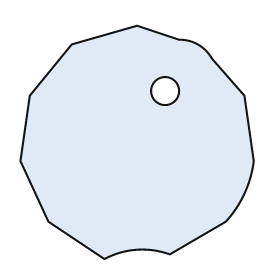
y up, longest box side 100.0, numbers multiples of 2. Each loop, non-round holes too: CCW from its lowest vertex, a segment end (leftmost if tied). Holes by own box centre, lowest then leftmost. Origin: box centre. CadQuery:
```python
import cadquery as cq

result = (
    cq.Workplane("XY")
    .moveTo(-14.0, -50.0)
    .threePointArc((0.0, -46.0), (14.0, -48.0))
    .lineTo(38.0, -34.0)
    .threePointArc((46.0, -22.0), (50.0, -8.0))
    .lineTo(46.0, 20.0)
    .lineTo(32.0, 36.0)
    .threePointArc((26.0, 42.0), (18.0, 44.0))
    .lineTo(0.0, 50.0)
    .lineTo(-28.0, 42.0)
    .lineTo(-46.0, 20.0)
    .lineTo(-50.0, -8.0)
    .lineTo(-38.0, -34.0)
    .close()
    .moveTo(12.0, 22.0)
    .circle(6.0)
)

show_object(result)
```